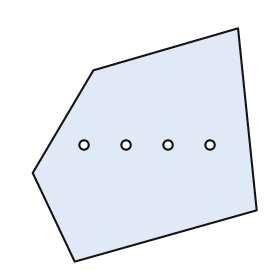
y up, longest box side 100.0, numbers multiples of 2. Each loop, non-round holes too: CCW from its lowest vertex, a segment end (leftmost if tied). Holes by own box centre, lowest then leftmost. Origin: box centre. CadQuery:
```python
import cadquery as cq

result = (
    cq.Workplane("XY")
    .moveTo(-30.0, -50.0)
    .lineTo(48.0, -28.0)
    .lineTo(40.0, 50.0)
    .lineTo(-22.0, 32.0)
    .lineTo(-48.0, -12.0)
    .close()
    .moveTo(-26.0, 0.0)
    .circle(2.0)
    .moveTo(-8.0, 0.0)
    .circle(2.0)
    .moveTo(10.0, 0.0)
    .circle(2.0)
    .moveTo(28.0, 0.0)
    .circle(2.0)
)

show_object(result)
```